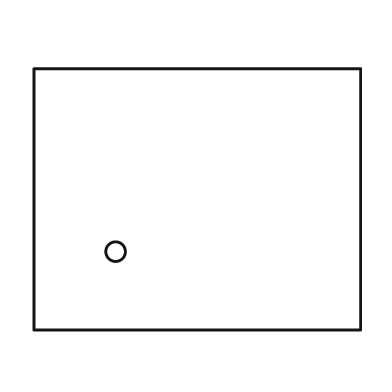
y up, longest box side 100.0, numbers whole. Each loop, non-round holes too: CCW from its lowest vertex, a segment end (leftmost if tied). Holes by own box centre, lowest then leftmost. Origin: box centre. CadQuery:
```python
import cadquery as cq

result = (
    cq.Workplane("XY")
    .moveTo(-50.0, -40.0)
    .lineTo(50.0, -40.0)
    .lineTo(50.0, 40.0)
    .lineTo(-50.0, 40.0)
    .close()
    .moveTo(-25.0, -16.0)
    .circle(3.0)
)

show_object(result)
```